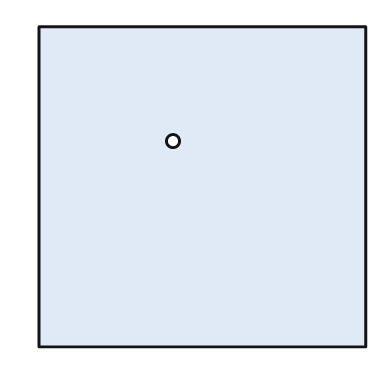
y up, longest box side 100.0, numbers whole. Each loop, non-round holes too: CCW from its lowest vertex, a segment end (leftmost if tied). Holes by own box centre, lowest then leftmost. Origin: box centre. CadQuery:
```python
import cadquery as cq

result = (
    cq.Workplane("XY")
    .moveTo(-50.0, -49.0)
    .lineTo(50.0, -49.0)
    .lineTo(50.0, 49.0)
    .lineTo(-50.0, 49.0)
    .close()
    .moveTo(-9.0, 14.0)
    .circle(2.0)
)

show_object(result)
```